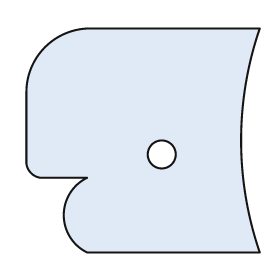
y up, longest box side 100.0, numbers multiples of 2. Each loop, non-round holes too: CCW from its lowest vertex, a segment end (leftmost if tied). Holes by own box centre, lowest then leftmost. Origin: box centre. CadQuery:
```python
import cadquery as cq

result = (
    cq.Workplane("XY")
    .moveTo(-24.0, -48.0)
    .lineTo(50.0, -48.0)
    .threePointArc((42.0, 0.0), (50.0, 48.0))
    .lineTo(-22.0, 48.0)
    .threePointArc((-42.0, 40.0), (-50.0, 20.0))
    .lineTo(-50.0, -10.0)
    .threePointArc((-48.0, -14.0), (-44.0, -16.0))
    .lineTo(-24.0, -16.0)
    .threePointArc((-34.0, -32.0), (-24.0, -48.0))
    .close()
    .moveTo(8.0, -6.0)
    .circle(6.0)
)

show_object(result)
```